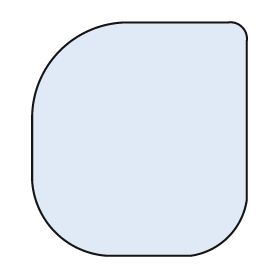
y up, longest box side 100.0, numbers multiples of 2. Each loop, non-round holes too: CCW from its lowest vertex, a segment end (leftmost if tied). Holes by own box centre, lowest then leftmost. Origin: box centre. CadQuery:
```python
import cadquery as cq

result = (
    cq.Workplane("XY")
    .moveTo(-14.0, -50.0)
    .lineTo(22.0, -50.0)
    .threePointArc((38.0, -42.0), (46.0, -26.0))
    .lineTo(46.0, 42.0)
    .threePointArc((44.0, 48.0), (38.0, 50.0))
    .lineTo(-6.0, 50.0)
    .threePointArc((-34.0, 38.0), (-46.0, 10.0))
    .lineTo(-46.0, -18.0)
    .threePointArc((-36.0, -40.0), (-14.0, -50.0))
    .close()
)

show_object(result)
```